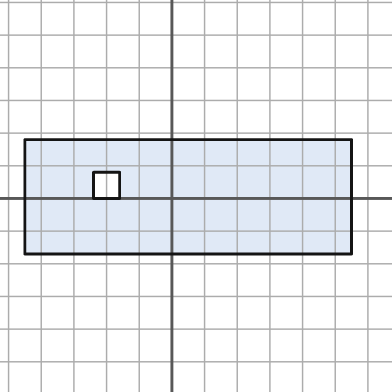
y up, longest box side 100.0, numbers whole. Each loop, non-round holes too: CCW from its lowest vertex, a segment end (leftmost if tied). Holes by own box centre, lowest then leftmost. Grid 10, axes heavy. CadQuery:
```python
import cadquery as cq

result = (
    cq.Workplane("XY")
    .moveTo(-45.0, -17.0)
    .lineTo(55.0, -17.0)
    .lineTo(55.0, 18.0)
    .lineTo(-45.0, 18.0)
    .close()
    .moveTo(-24.0, 0.0)
    .lineTo(-16.0, 0.0)
    .lineTo(-16.0, 8.0)
    .lineTo(-24.0, 8.0)
    .close()
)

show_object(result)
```